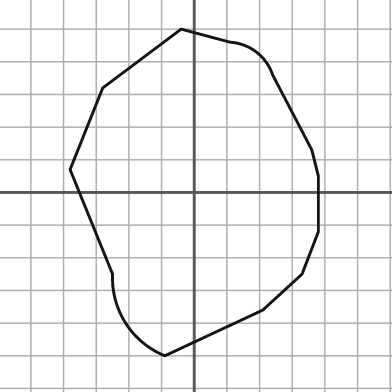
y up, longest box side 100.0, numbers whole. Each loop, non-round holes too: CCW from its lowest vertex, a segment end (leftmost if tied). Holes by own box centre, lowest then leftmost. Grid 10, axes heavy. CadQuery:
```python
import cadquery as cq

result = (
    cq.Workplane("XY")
    .moveTo(-9.0, -50.0)
    .lineTo(21.0, -36.0)
    .lineTo(33.0, -25.0)
    .lineTo(38.0, -12.0)
    .lineTo(38.0, 5.0)
    .lineTo(36.0, 13.0)
    .lineTo(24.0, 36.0)
    .threePointArc((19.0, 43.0), (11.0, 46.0))
    .lineTo(-4.0, 50.0)
    .lineTo(-28.0, 32.0)
    .lineTo(-38.0, 7.0)
    .lineTo(-25.0, -25.0)
    .threePointArc((-21.0, -40.0), (-9.0, -50.0))
    .close()
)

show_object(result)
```